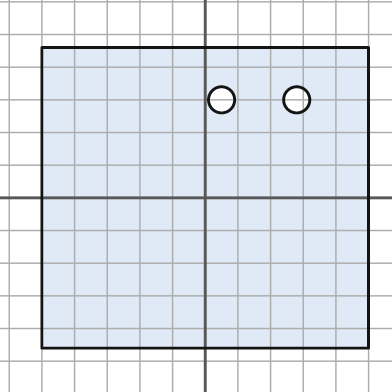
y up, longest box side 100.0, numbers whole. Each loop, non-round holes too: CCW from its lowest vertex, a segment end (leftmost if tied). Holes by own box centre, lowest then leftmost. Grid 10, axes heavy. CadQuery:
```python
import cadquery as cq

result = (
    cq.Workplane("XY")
    .moveTo(-50.0, -46.0)
    .lineTo(50.0, -46.0)
    .lineTo(50.0, 46.0)
    .lineTo(-50.0, 46.0)
    .close()
    .moveTo(5.0, 30.0)
    .circle(4.0)
    .moveTo(28.0, 30.0)
    .circle(4.0)
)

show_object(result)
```